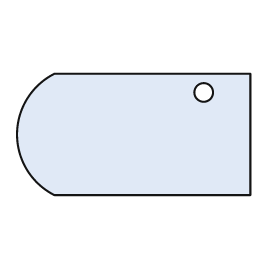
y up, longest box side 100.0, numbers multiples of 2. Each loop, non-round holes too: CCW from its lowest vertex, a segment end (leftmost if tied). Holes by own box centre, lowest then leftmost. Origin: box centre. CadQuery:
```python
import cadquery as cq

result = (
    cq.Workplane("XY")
    .moveTo(-34.0, -26.0)
    .lineTo(50.0, -26.0)
    .lineTo(50.0, 26.0)
    .lineTo(-34.0, 26.0)
    .threePointArc((-50.0, 0.0), (-34.0, -26.0))
    .close()
    .moveTo(30.0, 18.0)
    .circle(4.0)
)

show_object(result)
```